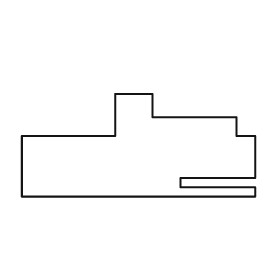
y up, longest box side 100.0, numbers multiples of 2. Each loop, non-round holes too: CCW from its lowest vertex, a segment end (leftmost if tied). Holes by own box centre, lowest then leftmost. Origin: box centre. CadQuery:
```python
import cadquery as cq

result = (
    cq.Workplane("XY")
    .moveTo(-50.0, -22.0)
    .lineTo(50.0, -22.0)
    .lineTo(50.0, -18.0)
    .lineTo(18.0, -18.0)
    .lineTo(18.0, -14.0)
    .lineTo(50.0, -14.0)
    .lineTo(50.0, 4.0)
    .lineTo(42.0, 4.0)
    .lineTo(42.0, 12.0)
    .lineTo(6.0, 12.0)
    .lineTo(6.0, 22.0)
    .lineTo(-10.0, 22.0)
    .lineTo(-10.0, 4.0)
    .lineTo(-50.0, 4.0)
    .close()
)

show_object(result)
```